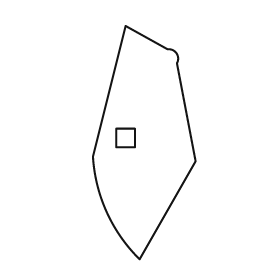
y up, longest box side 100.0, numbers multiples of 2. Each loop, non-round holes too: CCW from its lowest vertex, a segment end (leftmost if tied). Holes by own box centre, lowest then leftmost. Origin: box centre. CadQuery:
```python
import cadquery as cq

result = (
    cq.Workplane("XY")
    .moveTo(-2.0, -50.0)
    .lineTo(22.0, -8.0)
    .lineTo(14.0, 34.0)
    .threePointArc((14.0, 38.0), (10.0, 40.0))
    .lineTo(-8.0, 50.0)
    .lineTo(-22.0, -6.0)
    .threePointArc((-16.0, -30.0), (-2.0, -50.0))
    .close()
    .moveTo(-12.0, -2.0)
    .lineTo(-4.0, -2.0)
    .lineTo(-4.0, 6.0)
    .lineTo(-12.0, 6.0)
    .close()
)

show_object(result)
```